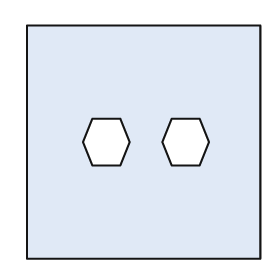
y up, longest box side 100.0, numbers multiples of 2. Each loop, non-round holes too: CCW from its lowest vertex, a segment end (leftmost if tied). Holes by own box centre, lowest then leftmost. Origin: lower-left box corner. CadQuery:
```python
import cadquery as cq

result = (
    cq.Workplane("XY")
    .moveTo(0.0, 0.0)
    .lineTo(100.0, 0.0)
    .lineTo(100.0, 100.0)
    .lineTo(0.0, 100.0)
    .close()
    .moveTo(28.0, 40.0)
    .lineTo(40.0, 40.0)
    .lineTo(44.0, 50.0)
    .lineTo(40.0, 60.0)
    .lineTo(28.0, 60.0)
    .lineTo(24.0, 50.0)
    .close()
    .moveTo(62.0, 40.0)
    .lineTo(74.0, 40.0)
    .lineTo(78.0, 50.0)
    .lineTo(74.0, 60.0)
    .lineTo(62.0, 60.0)
    .lineTo(58.0, 50.0)
    .close()
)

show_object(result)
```